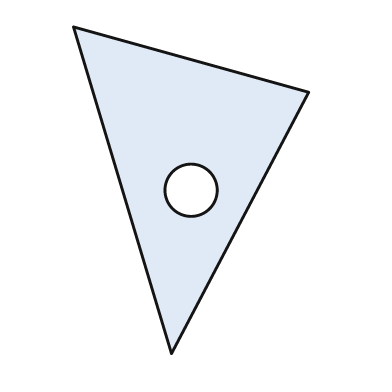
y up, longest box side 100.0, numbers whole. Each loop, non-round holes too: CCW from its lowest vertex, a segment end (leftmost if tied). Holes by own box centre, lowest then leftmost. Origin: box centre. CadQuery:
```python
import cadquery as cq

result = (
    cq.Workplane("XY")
    .moveTo(-6.0, -50.0)
    .lineTo(36.0, 30.0)
    .lineTo(-36.0, 50.0)
    .close()
    .moveTo(0.0, 0.0)
    .circle(8.0)
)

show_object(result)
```